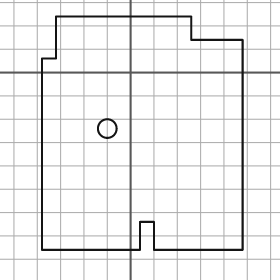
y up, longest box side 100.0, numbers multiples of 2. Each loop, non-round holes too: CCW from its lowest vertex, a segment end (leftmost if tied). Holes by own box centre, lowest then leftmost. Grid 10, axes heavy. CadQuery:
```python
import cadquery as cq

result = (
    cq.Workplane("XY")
    .moveTo(-38.0, -76.0)
    .lineTo(4.0, -76.0)
    .lineTo(4.0, -64.0)
    .lineTo(10.0, -64.0)
    .lineTo(10.0, -76.0)
    .lineTo(48.0, -76.0)
    .lineTo(48.0, 14.0)
    .lineTo(26.0, 14.0)
    .lineTo(26.0, 24.0)
    .lineTo(-32.0, 24.0)
    .lineTo(-32.0, 6.0)
    .lineTo(-38.0, 6.0)
    .close()
    .moveTo(-10.0, -24.0)
    .circle(4.0)
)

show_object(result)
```